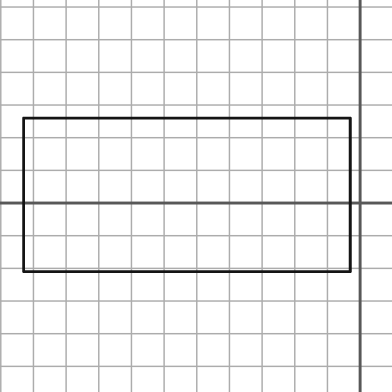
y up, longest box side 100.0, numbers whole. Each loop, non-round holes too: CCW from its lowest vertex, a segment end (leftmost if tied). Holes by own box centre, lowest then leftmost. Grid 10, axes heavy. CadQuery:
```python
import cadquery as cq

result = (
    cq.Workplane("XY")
    .moveTo(-103.0, -21.0)
    .lineTo(-3.0, -21.0)
    .lineTo(-3.0, 26.0)
    .lineTo(-103.0, 26.0)
    .close()
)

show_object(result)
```